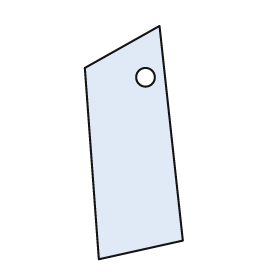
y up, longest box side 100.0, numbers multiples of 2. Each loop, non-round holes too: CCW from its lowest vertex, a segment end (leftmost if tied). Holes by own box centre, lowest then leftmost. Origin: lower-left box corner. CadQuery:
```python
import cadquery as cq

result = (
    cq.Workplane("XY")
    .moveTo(6.0, 0.0)
    .lineTo(42.0, 8.0)
    .lineTo(32.0, 100.0)
    .lineTo(0.0, 82.0)
    .close()
    .moveTo(26.0, 78.0)
    .circle(4.0)
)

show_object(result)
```